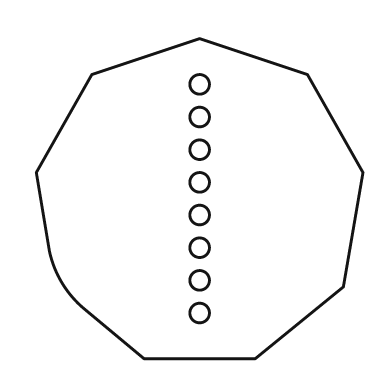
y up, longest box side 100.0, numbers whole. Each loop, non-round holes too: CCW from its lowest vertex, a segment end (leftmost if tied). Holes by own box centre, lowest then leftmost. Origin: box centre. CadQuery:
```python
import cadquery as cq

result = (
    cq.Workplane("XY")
    .moveTo(-17.0, -49.0)
    .lineTo(17.0, -49.0)
    .lineTo(44.0, -27.0)
    .lineTo(50.0, 8.0)
    .lineTo(33.0, 38.0)
    .lineTo(0.0, 49.0)
    .lineTo(-33.0, 38.0)
    .lineTo(-50.0, 8.0)
    .lineTo(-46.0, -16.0)
    .threePointArc((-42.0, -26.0), (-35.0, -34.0))
    .close()
    .moveTo(0.0, -35.0)
    .circle(3.0)
    .moveTo(0.0, -25.0)
    .circle(3.0)
    .moveTo(0.0, -15.0)
    .circle(3.0)
    .moveTo(0.0, -5.0)
    .circle(3.0)
    .moveTo(0.0, 5.0)
    .circle(3.0)
    .moveTo(0.0, 15.0)
    .circle(3.0)
    .moveTo(0.0, 25.0)
    .circle(3.0)
    .moveTo(0.0, 35.0)
    .circle(3.0)
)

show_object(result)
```